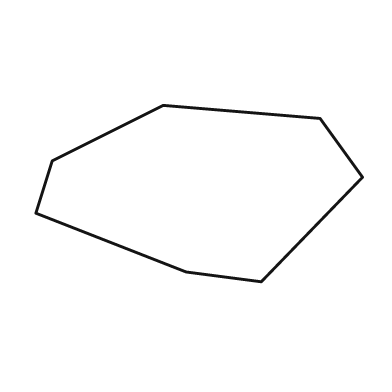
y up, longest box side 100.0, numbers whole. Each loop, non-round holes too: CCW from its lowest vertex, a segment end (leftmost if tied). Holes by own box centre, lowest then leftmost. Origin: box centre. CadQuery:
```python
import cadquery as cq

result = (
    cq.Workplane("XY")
    .moveTo(19.0, -27.0)
    .lineTo(50.0, 5.0)
    .lineTo(37.0, 23.0)
    .lineTo(-11.0, 27.0)
    .lineTo(-45.0, 10.0)
    .lineTo(-50.0, -6.0)
    .lineTo(-4.0, -24.0)
    .close()
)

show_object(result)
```